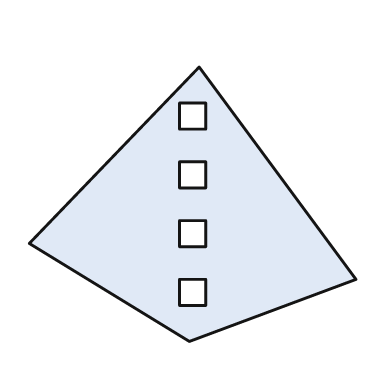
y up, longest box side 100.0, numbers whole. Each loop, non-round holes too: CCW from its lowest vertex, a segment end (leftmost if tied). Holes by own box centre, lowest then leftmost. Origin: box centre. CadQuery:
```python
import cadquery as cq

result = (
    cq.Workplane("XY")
    .moveTo(-1.0, -42.0)
    .lineTo(50.0, -23.0)
    .lineTo(2.0, 42.0)
    .lineTo(-50.0, -12.0)
    .close()
    .moveTo(-4.0, -31.0)
    .lineTo(4.0, -31.0)
    .lineTo(4.0, -23.0)
    .lineTo(-4.0, -23.0)
    .close()
    .moveTo(-4.0, -13.0)
    .lineTo(4.0, -13.0)
    .lineTo(4.0, -5.0)
    .lineTo(-4.0, -5.0)
    .close()
    .moveTo(-4.0, 5.0)
    .lineTo(4.0, 5.0)
    .lineTo(4.0, 13.0)
    .lineTo(-4.0, 13.0)
    .close()
    .moveTo(-4.0, 23.0)
    .lineTo(4.0, 23.0)
    .lineTo(4.0, 31.0)
    .lineTo(-4.0, 31.0)
    .close()
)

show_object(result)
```